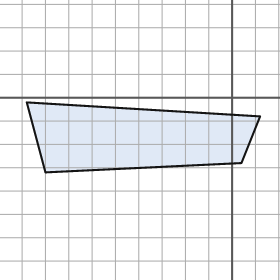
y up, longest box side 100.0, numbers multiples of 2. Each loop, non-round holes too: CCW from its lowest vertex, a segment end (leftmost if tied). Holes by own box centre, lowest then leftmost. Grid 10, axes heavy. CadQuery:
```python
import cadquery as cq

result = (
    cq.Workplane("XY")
    .moveTo(-80.0, -32.0)
    .lineTo(4.0, -28.0)
    .lineTo(12.0, -8.0)
    .lineTo(-88.0, -2.0)
    .close()
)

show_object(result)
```